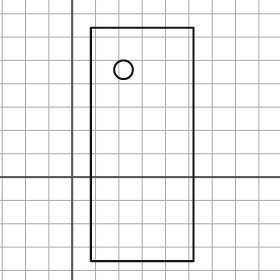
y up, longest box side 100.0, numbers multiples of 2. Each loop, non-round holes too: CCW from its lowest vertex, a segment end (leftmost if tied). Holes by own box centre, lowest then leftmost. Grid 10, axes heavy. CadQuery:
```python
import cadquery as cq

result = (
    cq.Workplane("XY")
    .moveTo(8.0, -36.0)
    .lineTo(52.0, -36.0)
    .lineTo(52.0, 64.0)
    .lineTo(8.0, 64.0)
    .close()
    .moveTo(22.0, 46.0)
    .circle(4.0)
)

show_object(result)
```